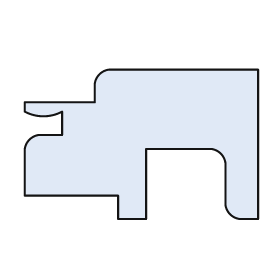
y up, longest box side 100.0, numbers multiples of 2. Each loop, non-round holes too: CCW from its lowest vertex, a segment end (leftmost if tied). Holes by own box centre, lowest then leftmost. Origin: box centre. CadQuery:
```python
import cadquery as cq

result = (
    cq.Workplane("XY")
    .moveTo(-10.0, -32.0)
    .lineTo(2.0, -32.0)
    .lineTo(2.0, -2.0)
    .lineTo(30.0, -2.0)
    .threePointArc((34.0, -4.0), (36.0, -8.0))
    .lineTo(36.0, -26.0)
    .threePointArc((38.0, -30.0), (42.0, -32.0))
    .lineTo(50.0, -32.0)
    .lineTo(50.0, 32.0)
    .lineTo(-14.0, 32.0)
    .threePointArc((-18.0, 30.0), (-20.0, 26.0))
    .lineTo(-20.0, 18.0)
    .lineTo(-50.0, 18.0)
    .lineTo(-50.0, 14.0)
    .threePointArc((-42.0, 12.0), (-34.0, 14.0))
    .lineTo(-34.0, 4.0)
    .lineTo(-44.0, 4.0)
    .threePointArc((-48.0, 2.0), (-50.0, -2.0))
    .lineTo(-50.0, -22.0)
    .lineTo(-10.0, -22.0)
    .close()
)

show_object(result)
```